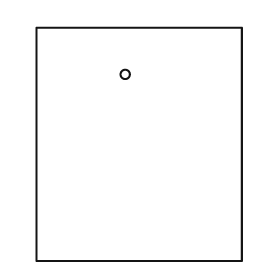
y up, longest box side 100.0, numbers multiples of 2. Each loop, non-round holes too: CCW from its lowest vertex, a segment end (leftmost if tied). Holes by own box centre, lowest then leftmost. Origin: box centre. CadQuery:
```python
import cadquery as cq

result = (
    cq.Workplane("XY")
    .moveTo(-44.0, -50.0)
    .lineTo(44.0, -50.0)
    .lineTo(44.0, 50.0)
    .lineTo(-44.0, 50.0)
    .close()
    .moveTo(-6.0, 30.0)
    .circle(2.0)
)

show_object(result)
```